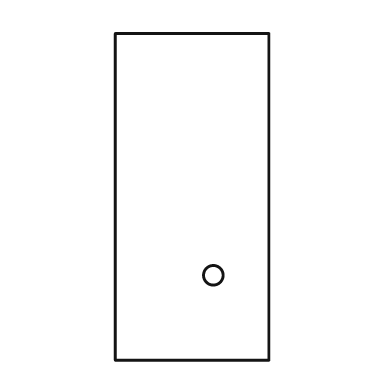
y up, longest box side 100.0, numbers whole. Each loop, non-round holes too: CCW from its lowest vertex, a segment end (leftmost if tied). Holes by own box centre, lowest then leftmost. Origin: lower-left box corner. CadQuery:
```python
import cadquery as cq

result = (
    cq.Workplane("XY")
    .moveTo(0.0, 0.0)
    .lineTo(47.0, 0.0)
    .lineTo(47.0, 100.0)
    .lineTo(0.0, 100.0)
    .close()
    .moveTo(30.0, 26.0)
    .circle(3.0)
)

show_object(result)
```